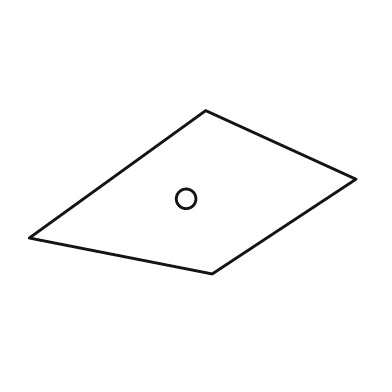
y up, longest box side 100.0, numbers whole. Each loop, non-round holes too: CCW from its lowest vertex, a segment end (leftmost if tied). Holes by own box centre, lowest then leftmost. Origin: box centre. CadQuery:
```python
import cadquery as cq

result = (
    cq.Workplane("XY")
    .moveTo(6.0, -25.0)
    .lineTo(50.0, 4.0)
    .lineTo(4.0, 25.0)
    .lineTo(-50.0, -14.0)
    .close()
    .moveTo(-2.0, -2.0)
    .circle(3.0)
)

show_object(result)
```